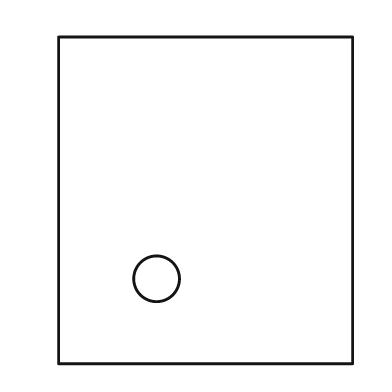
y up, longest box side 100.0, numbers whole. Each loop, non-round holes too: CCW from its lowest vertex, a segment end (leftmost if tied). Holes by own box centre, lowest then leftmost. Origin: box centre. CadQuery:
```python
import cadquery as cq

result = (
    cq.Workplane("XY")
    .moveTo(-45.0, -50.0)
    .lineTo(45.0, -50.0)
    .lineTo(45.0, 50.0)
    .lineTo(-45.0, 50.0)
    .close()
    .moveTo(-15.0, -24.0)
    .circle(7.0)
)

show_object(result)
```